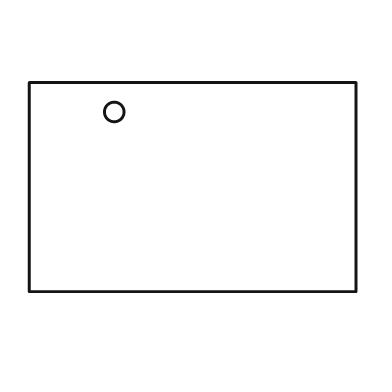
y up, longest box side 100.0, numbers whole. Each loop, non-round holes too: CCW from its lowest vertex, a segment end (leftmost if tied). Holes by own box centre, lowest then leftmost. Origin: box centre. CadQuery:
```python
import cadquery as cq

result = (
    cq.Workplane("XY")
    .moveTo(-50.0, -32.0)
    .lineTo(50.0, -32.0)
    .lineTo(50.0, 32.0)
    .lineTo(-50.0, 32.0)
    .close()
    .moveTo(-24.0, 23.0)
    .circle(3.0)
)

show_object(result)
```